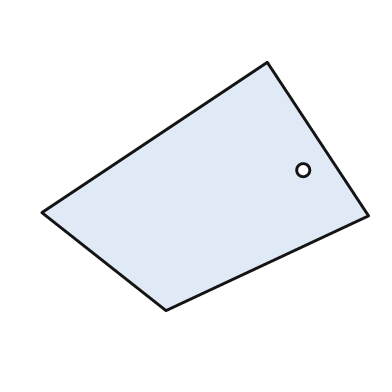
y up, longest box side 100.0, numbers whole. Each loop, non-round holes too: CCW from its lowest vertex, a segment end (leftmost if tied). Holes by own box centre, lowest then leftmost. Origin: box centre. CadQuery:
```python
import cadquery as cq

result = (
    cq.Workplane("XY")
    .moveTo(-12.0, -38.0)
    .lineTo(50.0, -9.0)
    .lineTo(19.0, 38.0)
    .lineTo(-50.0, -8.0)
    .close()
    .moveTo(30.0, 5.0)
    .circle(2.0)
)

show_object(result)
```